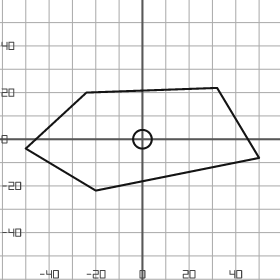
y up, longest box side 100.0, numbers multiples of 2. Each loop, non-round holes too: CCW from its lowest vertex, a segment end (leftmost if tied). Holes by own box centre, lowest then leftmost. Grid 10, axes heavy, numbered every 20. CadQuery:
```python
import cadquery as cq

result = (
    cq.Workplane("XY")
    .moveTo(-20.0, -22.0)
    .lineTo(50.0, -8.0)
    .lineTo(32.0, 22.0)
    .lineTo(-24.0, 20.0)
    .lineTo(-50.0, -4.0)
    .close()
    .moveTo(0.0, 0.0)
    .circle(4.0)
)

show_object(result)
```